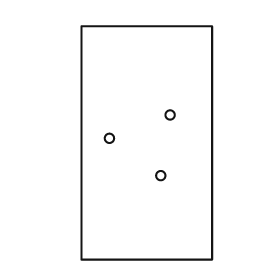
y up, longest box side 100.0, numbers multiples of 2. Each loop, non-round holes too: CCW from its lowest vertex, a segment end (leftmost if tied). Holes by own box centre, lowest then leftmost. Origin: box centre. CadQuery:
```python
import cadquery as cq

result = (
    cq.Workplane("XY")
    .moveTo(-28.0, -50.0)
    .lineTo(28.0, -50.0)
    .lineTo(28.0, 50.0)
    .lineTo(-28.0, 50.0)
    .close()
    .moveTo(6.0, -14.0)
    .circle(2.0)
    .moveTo(-16.0, 2.0)
    .circle(2.0)
    .moveTo(10.0, 12.0)
    .circle(2.0)
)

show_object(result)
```